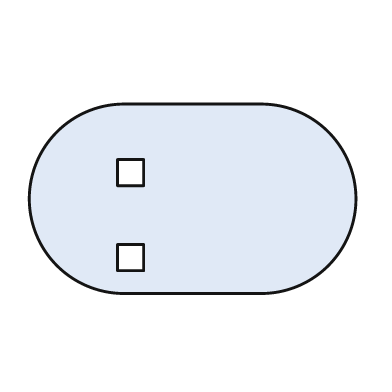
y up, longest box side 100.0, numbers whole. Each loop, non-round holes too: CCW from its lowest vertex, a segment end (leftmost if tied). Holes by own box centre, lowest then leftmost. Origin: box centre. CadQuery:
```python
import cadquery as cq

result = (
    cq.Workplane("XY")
    .moveTo(-21.0, -29.0)
    .lineTo(21.0, -29.0)
    .threePointArc((50.0, 0.0), (21.0, 29.0))
    .lineTo(-21.0, 29.0)
    .threePointArc((-50.0, 0.0), (-21.0, -29.0))
    .close()
    .moveTo(-23.0, -22.0)
    .lineTo(-15.0, -22.0)
    .lineTo(-15.0, -14.0)
    .lineTo(-23.0, -14.0)
    .close()
    .moveTo(-23.0, 4.0)
    .lineTo(-15.0, 4.0)
    .lineTo(-15.0, 12.0)
    .lineTo(-23.0, 12.0)
    .close()
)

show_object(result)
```